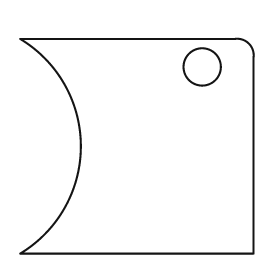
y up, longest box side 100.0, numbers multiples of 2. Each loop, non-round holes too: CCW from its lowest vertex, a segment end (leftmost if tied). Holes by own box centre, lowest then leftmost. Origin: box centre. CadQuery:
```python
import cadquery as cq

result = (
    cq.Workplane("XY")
    .moveTo(-50.0, -46.0)
    .lineTo(50.0, -46.0)
    .lineTo(50.0, 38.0)
    .threePointArc((48.0, 44.0), (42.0, 46.0))
    .lineTo(-50.0, 46.0)
    .threePointArc((-24.0, 0.0), (-50.0, -46.0))
    .close()
    .moveTo(28.0, 34.0)
    .circle(8.0)
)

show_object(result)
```